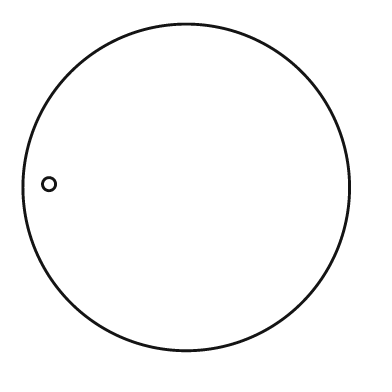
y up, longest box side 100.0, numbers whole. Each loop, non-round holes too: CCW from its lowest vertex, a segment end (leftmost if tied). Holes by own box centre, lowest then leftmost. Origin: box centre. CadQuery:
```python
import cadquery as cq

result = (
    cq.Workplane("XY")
    .moveTo(0.0, 0.0)
    .circle(50.0)
    .moveTo(-42.0, 1.0)
    .circle(2.0)
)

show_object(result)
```